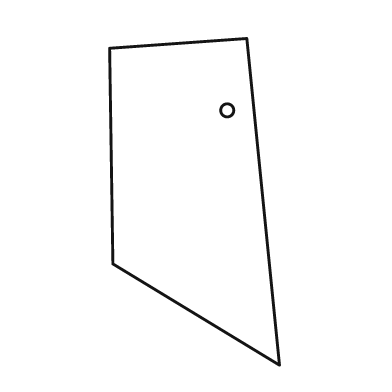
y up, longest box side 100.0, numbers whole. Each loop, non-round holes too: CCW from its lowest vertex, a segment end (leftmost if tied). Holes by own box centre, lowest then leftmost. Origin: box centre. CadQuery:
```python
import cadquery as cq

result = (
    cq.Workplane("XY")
    .moveTo(26.0, -50.0)
    .lineTo(16.0, 50.0)
    .lineTo(-26.0, 47.0)
    .lineTo(-25.0, -19.0)
    .close()
    .moveTo(10.0, 28.0)
    .circle(2.0)
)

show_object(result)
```